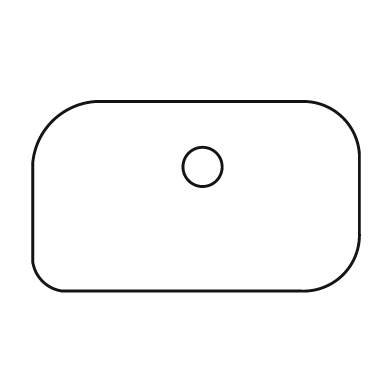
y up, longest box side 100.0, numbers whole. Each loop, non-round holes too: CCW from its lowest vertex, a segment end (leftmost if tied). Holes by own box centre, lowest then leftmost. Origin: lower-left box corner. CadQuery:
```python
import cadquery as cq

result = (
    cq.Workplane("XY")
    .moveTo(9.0, 0.0)
    .lineTo(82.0, 0.0)
    .threePointArc((95.0, 5.0), (100.0, 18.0))
    .lineTo(100.0, 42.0)
    .threePointArc((95.0, 53.0), (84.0, 58.0))
    .lineTo(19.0, 58.0)
    .threePointArc((6.0, 52.0), (0.0, 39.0))
    .lineTo(0.0, 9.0)
    .threePointArc((3.0, 3.0), (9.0, 0.0))
    .close()
    .moveTo(52.0, 38.0)
    .circle(6.0)
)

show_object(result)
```